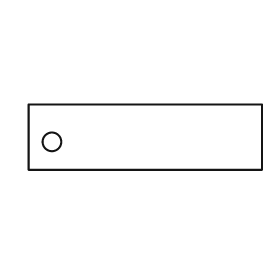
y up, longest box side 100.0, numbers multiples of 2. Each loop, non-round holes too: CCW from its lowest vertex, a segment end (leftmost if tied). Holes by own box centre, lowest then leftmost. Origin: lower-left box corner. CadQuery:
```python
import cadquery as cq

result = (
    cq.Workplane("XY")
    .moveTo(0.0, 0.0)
    .lineTo(100.0, 0.0)
    .lineTo(100.0, 28.0)
    .lineTo(0.0, 28.0)
    .close()
    .moveTo(10.0, 12.0)
    .circle(4.0)
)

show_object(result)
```